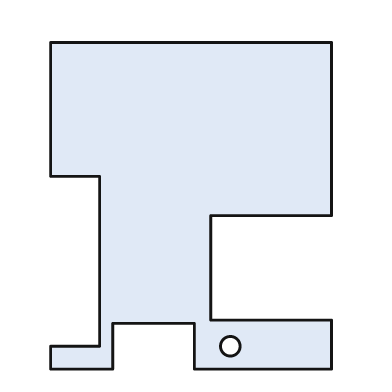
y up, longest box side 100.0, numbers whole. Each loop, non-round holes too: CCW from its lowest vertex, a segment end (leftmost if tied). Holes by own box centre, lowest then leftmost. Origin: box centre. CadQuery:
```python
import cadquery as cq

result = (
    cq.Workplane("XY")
    .moveTo(-43.0, -50.0)
    .lineTo(-24.0, -50.0)
    .lineTo(-24.0, -36.0)
    .lineTo(1.0, -36.0)
    .lineTo(1.0, -50.0)
    .lineTo(43.0, -50.0)
    .lineTo(43.0, -35.0)
    .lineTo(6.0, -35.0)
    .lineTo(6.0, -3.0)
    .lineTo(43.0, -3.0)
    .lineTo(43.0, 50.0)
    .lineTo(-43.0, 50.0)
    .lineTo(-43.0, 9.0)
    .lineTo(-28.0, 9.0)
    .lineTo(-28.0, -43.0)
    .lineTo(-43.0, -43.0)
    .close()
    .moveTo(12.0, -43.0)
    .circle(3.0)
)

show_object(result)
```